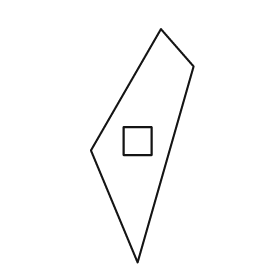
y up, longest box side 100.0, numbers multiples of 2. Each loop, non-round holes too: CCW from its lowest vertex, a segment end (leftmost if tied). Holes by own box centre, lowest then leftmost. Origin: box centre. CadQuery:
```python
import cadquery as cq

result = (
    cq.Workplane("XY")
    .moveTo(-2.0, -50.0)
    .lineTo(22.0, 34.0)
    .lineTo(8.0, 50.0)
    .lineTo(-22.0, -2.0)
    .close()
    .moveTo(-8.0, -4.0)
    .lineTo(4.0, -4.0)
    .lineTo(4.0, 8.0)
    .lineTo(-8.0, 8.0)
    .close()
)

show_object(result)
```